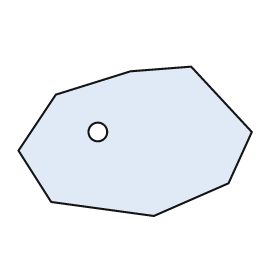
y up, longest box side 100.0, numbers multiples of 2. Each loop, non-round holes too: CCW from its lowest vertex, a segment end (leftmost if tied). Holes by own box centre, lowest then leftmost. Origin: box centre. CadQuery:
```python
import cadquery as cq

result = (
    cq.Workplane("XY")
    .moveTo(8.0, -32.0)
    .lineTo(40.0, -18.0)
    .lineTo(50.0, 4.0)
    .lineTo(24.0, 32.0)
    .lineTo(-2.0, 30.0)
    .lineTo(-34.0, 20.0)
    .lineTo(-50.0, -4.0)
    .lineTo(-36.0, -26.0)
    .close()
    .moveTo(-16.0, 4.0)
    .circle(4.0)
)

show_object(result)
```